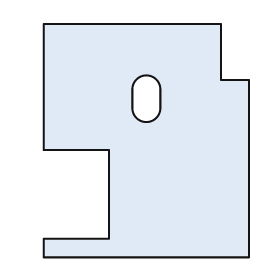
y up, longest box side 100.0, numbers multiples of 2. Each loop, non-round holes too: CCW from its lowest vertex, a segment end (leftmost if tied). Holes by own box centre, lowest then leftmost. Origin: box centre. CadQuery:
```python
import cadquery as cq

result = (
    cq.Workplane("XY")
    .moveTo(-44.0, -50.0)
    .lineTo(44.0, -50.0)
    .lineTo(44.0, 26.0)
    .lineTo(32.0, 26.0)
    .lineTo(32.0, 50.0)
    .lineTo(-44.0, 50.0)
    .lineTo(-44.0, -4.0)
    .lineTo(-16.0, -4.0)
    .lineTo(-16.0, -42.0)
    .lineTo(-44.0, -42.0)
    .close()
    .moveTo(-6.0, 14.0)
    .threePointArc((0.0, 8.0), (6.0, 14.0))
    .lineTo(6.0, 22.0)
    .threePointArc((0.0, 28.0), (-6.0, 22.0))
    .close()
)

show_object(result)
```